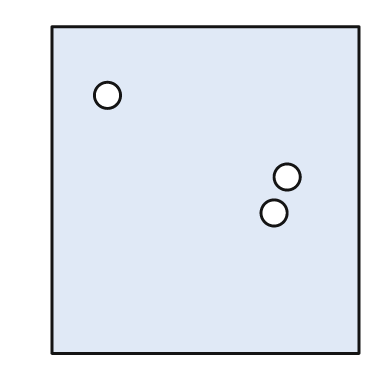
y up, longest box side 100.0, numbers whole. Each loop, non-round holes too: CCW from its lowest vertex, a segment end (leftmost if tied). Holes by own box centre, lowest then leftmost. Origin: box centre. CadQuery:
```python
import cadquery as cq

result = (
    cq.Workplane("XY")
    .moveTo(-47.0, -50.0)
    .lineTo(47.0, -50.0)
    .lineTo(47.0, 50.0)
    .lineTo(-47.0, 50.0)
    .close()
    .moveTo(21.0, -7.0)
    .circle(4.0)
    .moveTo(25.0, 4.0)
    .circle(4.0)
    .moveTo(-30.0, 29.0)
    .circle(4.0)
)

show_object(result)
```